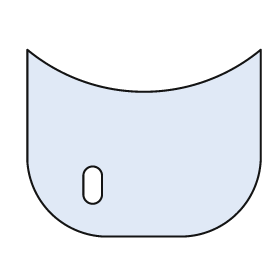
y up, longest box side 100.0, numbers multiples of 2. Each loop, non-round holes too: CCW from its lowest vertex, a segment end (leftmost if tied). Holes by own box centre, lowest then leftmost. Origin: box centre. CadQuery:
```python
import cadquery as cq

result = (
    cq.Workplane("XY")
    .moveTo(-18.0, -40.0)
    .lineTo(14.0, -40.0)
    .threePointArc((40.0, -30.0), (50.0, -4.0))
    .lineTo(50.0, 40.0)
    .threePointArc((0.0, 22.0), (-50.0, 40.0))
    .lineTo(-50.0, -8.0)
    .threePointArc((-40.0, -30.0), (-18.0, -40.0))
    .close()
    .moveTo(-26.0, -22.0)
    .threePointArc((-22.0, -26.0), (-18.0, -22.0))
    .lineTo(-18.0, -14.0)
    .threePointArc((-22.0, -10.0), (-26.0, -14.0))
    .close()
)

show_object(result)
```